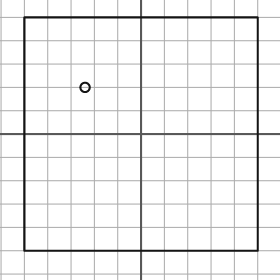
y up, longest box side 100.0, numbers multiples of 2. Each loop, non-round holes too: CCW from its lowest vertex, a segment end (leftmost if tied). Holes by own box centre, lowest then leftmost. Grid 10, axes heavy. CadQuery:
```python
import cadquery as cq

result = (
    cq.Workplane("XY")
    .moveTo(-50.0, -50.0)
    .lineTo(50.0, -50.0)
    .lineTo(50.0, 50.0)
    .lineTo(-50.0, 50.0)
    .close()
    .moveTo(-24.0, 20.0)
    .circle(2.0)
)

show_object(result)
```